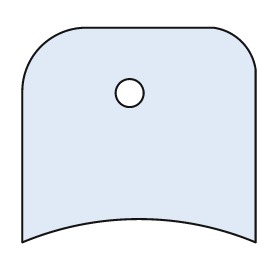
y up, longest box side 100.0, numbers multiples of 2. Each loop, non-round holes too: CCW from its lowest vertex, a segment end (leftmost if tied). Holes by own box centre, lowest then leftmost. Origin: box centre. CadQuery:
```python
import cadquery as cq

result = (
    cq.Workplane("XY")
    .moveTo(-50.0, -46.0)
    .threePointArc((0.0, -36.0), (50.0, -46.0))
    .lineTo(50.0, 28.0)
    .threePointArc((44.0, 40.0), (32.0, 46.0))
    .lineTo(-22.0, 46.0)
    .threePointArc((-42.0, 38.0), (-50.0, 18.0))
    .close()
    .moveTo(-4.0, 18.0)
    .circle(6.0)
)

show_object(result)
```